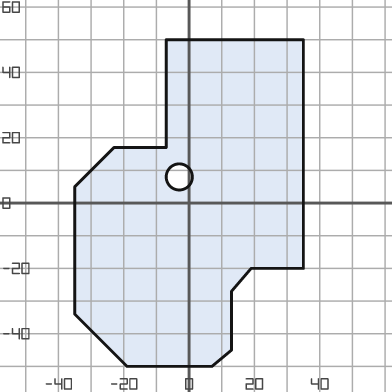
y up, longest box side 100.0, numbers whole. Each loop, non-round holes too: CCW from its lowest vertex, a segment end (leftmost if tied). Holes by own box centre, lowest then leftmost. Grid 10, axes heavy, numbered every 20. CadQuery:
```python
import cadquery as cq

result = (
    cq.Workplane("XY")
    .moveTo(-19.0, -50.0)
    .lineTo(7.0, -50.0)
    .lineTo(13.0, -45.0)
    .lineTo(13.0, -27.0)
    .lineTo(19.0, -20.0)
    .lineTo(35.0, -20.0)
    .lineTo(35.0, 50.0)
    .lineTo(-7.0, 50.0)
    .lineTo(-7.0, 17.0)
    .lineTo(-23.0, 17.0)
    .lineTo(-35.0, 5.0)
    .lineTo(-35.0, -34.0)
    .close()
    .moveTo(-3.0, 8.0)
    .circle(4.0)
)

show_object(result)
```